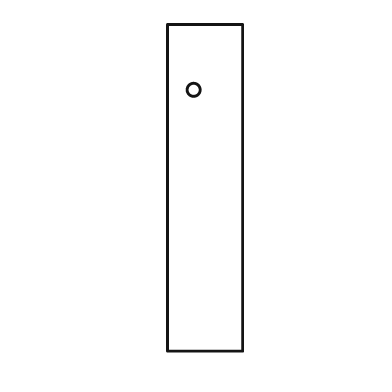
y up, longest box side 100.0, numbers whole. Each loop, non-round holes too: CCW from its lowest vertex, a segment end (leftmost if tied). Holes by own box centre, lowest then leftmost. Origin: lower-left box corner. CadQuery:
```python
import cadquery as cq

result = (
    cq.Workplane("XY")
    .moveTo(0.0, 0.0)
    .lineTo(23.0, 0.0)
    .lineTo(23.0, 100.0)
    .lineTo(0.0, 100.0)
    .close()
    .moveTo(8.0, 80.0)
    .circle(2.0)
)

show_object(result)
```